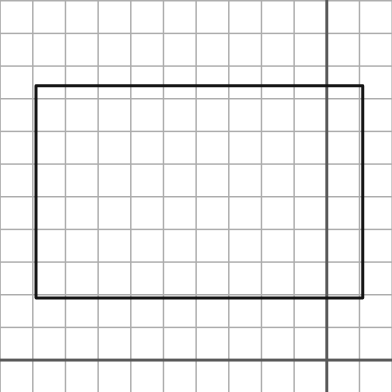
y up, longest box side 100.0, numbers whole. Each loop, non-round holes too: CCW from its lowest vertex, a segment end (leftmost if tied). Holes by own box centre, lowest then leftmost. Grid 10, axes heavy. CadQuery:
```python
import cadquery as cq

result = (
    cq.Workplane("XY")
    .moveTo(-89.0, 19.0)
    .lineTo(11.0, 19.0)
    .lineTo(11.0, 84.0)
    .lineTo(-89.0, 84.0)
    .close()
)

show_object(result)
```